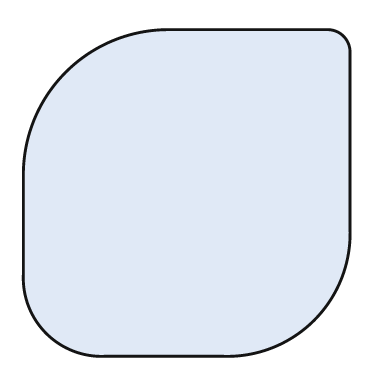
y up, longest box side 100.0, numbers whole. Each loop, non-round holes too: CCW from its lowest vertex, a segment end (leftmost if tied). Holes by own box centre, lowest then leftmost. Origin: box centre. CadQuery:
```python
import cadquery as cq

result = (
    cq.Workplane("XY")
    .moveTo(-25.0, -50.0)
    .lineTo(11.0, -50.0)
    .threePointArc((39.0, -39.0), (50.0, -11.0))
    .lineTo(50.0, 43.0)
    .threePointArc((48.0, 48.0), (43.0, 50.0))
    .lineTo(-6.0, 50.0)
    .threePointArc((-37.0, 37.0), (-50.0, 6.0))
    .lineTo(-50.0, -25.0)
    .threePointArc((-43.0, -43.0), (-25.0, -50.0))
    .close()
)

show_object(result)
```